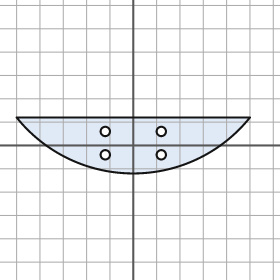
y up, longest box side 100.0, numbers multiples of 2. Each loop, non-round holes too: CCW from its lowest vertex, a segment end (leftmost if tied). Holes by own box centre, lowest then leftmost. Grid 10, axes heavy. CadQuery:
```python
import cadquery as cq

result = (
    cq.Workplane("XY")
    .moveTo(-50.0, 12.0)
    .threePointArc((0.0, -12.0), (50.0, 12.0))
    .close()
    .moveTo(-12.0, -4.0)
    .circle(2.0)
    .moveTo(12.0, -4.0)
    .circle(2.0)
    .moveTo(-12.0, 6.0)
    .circle(2.0)
    .moveTo(12.0, 6.0)
    .circle(2.0)
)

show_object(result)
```